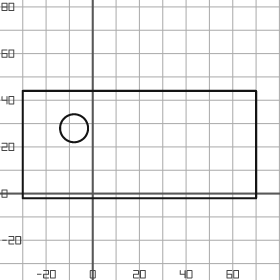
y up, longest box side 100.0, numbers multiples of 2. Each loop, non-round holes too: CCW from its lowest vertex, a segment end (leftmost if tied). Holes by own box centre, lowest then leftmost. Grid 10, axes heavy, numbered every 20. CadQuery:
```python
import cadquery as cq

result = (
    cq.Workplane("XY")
    .moveTo(-30.0, -2.0)
    .lineTo(70.0, -2.0)
    .lineTo(70.0, 44.0)
    .lineTo(-30.0, 44.0)
    .close()
    .moveTo(-8.0, 28.0)
    .circle(6.0)
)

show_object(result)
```